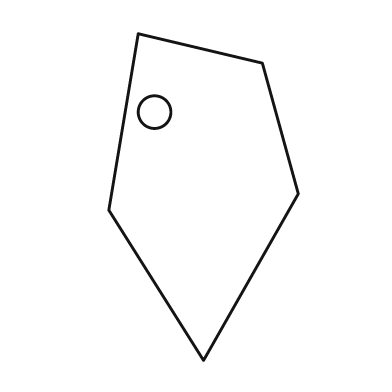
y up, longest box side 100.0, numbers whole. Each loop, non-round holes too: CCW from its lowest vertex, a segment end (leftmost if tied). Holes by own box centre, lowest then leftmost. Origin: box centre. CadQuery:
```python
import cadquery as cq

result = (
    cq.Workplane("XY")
    .moveTo(0.0, -50.0)
    .lineTo(29.0, 1.0)
    .lineTo(18.0, 41.0)
    .lineTo(-20.0, 50.0)
    .lineTo(-29.0, -4.0)
    .close()
    .moveTo(-15.0, 26.0)
    .circle(5.0)
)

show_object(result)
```